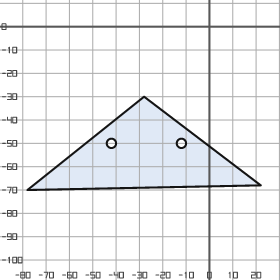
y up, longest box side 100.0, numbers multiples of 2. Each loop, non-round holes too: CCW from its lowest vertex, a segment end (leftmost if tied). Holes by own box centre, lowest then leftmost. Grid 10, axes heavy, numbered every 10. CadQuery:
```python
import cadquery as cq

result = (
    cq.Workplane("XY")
    .moveTo(-78.0, -70.0)
    .lineTo(22.0, -68.0)
    .lineTo(-28.0, -30.0)
    .close()
    .moveTo(-42.0, -50.0)
    .circle(2.0)
    .moveTo(-12.0, -50.0)
    .circle(2.0)
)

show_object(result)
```